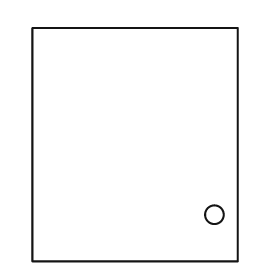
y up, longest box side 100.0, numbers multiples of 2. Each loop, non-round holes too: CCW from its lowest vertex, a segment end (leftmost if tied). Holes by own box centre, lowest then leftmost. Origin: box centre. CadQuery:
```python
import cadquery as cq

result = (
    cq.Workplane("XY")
    .moveTo(-44.0, -50.0)
    .lineTo(44.0, -50.0)
    .lineTo(44.0, 50.0)
    .lineTo(-44.0, 50.0)
    .close()
    .moveTo(34.0, -30.0)
    .circle(4.0)
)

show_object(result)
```